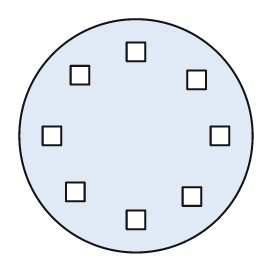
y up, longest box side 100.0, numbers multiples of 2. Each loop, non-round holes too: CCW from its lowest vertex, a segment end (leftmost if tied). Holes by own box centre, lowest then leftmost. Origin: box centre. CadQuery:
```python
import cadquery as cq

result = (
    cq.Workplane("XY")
    .moveTo(0.0, 0.0)
    .circle(50.0)
    .moveTo(-4.0, -40.0)
    .lineTo(4.0, -40.0)
    .lineTo(4.0, -32.0)
    .lineTo(-4.0, -32.0)
    .close()
    .moveTo(20.0, -30.0)
    .lineTo(28.0, -30.0)
    .lineTo(28.0, -22.0)
    .lineTo(20.0, -22.0)
    .close()
    .moveTo(-30.0, -28.0)
    .lineTo(-22.0, -28.0)
    .lineTo(-22.0, -20.0)
    .lineTo(-30.0, -20.0)
    .close()
    .moveTo(-40.0, -4.0)
    .lineTo(-32.0, -4.0)
    .lineTo(-32.0, 4.0)
    .lineTo(-40.0, 4.0)
    .close()
    .moveTo(32.0, -4.0)
    .lineTo(40.0, -4.0)
    .lineTo(40.0, 4.0)
    .lineTo(32.0, 4.0)
    .close()
    .moveTo(22.0, 20.0)
    .lineTo(30.0, 20.0)
    .lineTo(30.0, 28.0)
    .lineTo(22.0, 28.0)
    .close()
    .moveTo(-28.0, 22.0)
    .lineTo(-20.0, 22.0)
    .lineTo(-20.0, 30.0)
    .lineTo(-28.0, 30.0)
    .close()
    .moveTo(-4.0, 32.0)
    .lineTo(4.0, 32.0)
    .lineTo(4.0, 40.0)
    .lineTo(-4.0, 40.0)
    .close()
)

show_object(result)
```